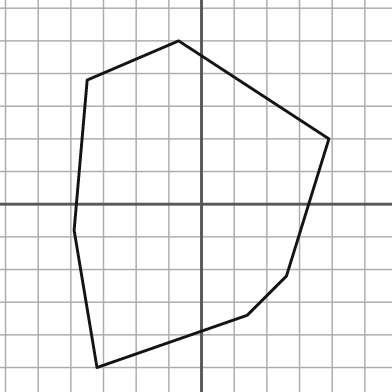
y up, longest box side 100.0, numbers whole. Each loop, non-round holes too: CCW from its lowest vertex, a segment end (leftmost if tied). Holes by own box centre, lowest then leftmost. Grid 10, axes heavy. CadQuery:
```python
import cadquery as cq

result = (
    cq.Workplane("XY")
    .moveTo(-32.0, -50.0)
    .lineTo(14.0, -34.0)
    .lineTo(26.0, -22.0)
    .lineTo(39.0, 20.0)
    .lineTo(-7.0, 50.0)
    .lineTo(-35.0, 38.0)
    .lineTo(-39.0, -8.0)
    .close()
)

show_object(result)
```